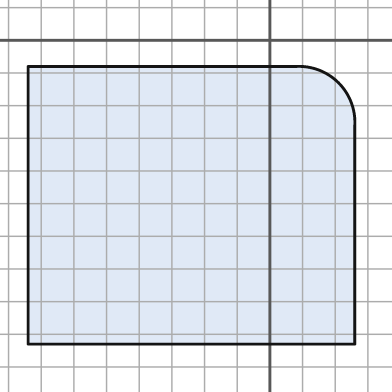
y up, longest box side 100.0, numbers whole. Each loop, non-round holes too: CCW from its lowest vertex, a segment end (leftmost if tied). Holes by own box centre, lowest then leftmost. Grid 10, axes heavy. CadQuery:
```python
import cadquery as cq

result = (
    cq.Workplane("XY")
    .moveTo(-74.0, -93.0)
    .lineTo(26.0, -93.0)
    .lineTo(26.0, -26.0)
    .threePointArc((21.0, -13.0), (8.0, -8.0))
    .lineTo(-74.0, -8.0)
    .close()
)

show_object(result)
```